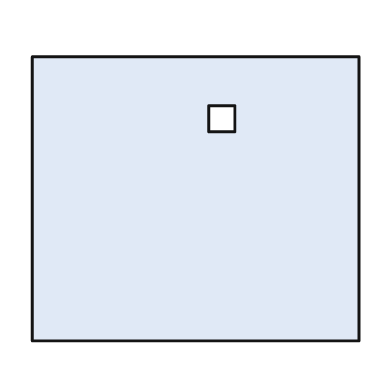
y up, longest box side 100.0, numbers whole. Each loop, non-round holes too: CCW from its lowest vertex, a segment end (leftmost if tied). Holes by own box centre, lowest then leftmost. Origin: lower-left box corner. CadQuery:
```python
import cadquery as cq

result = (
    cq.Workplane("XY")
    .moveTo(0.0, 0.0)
    .lineTo(100.0, 0.0)
    .lineTo(100.0, 87.0)
    .lineTo(0.0, 87.0)
    .close()
    .moveTo(54.0, 64.0)
    .lineTo(62.0, 64.0)
    .lineTo(62.0, 72.0)
    .lineTo(54.0, 72.0)
    .close()
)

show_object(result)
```